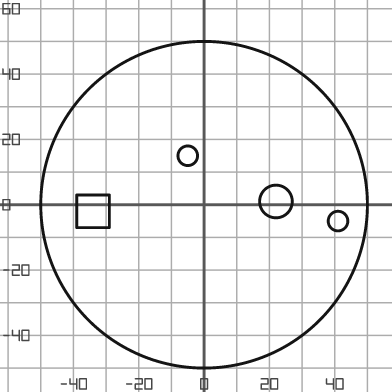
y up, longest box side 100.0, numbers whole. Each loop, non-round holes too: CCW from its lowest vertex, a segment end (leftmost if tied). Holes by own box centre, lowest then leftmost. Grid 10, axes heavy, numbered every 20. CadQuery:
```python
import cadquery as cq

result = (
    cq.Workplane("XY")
    .moveTo(0.0, 0.0)
    .circle(50.0)
    .moveTo(41.0, -5.0)
    .circle(3.0)
    .moveTo(-39.0, -7.0)
    .lineTo(-29.0, -7.0)
    .lineTo(-29.0, 3.0)
    .lineTo(-39.0, 3.0)
    .close()
    .moveTo(22.0, 1.0)
    .circle(5.0)
    .moveTo(-5.0, 15.0)
    .circle(3.0)
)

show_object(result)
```